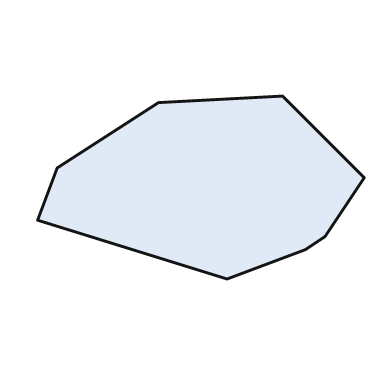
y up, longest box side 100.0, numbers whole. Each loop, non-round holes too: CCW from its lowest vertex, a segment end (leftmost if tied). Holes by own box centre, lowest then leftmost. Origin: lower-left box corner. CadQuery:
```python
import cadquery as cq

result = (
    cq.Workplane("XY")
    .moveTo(58.0, 0.0)
    .lineTo(82.0, 9.0)
    .lineTo(88.0, 13.0)
    .lineTo(100.0, 31.0)
    .lineTo(75.0, 56.0)
    .lineTo(37.0, 54.0)
    .lineTo(6.0, 34.0)
    .lineTo(0.0, 18.0)
    .close()
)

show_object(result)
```